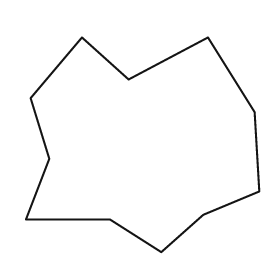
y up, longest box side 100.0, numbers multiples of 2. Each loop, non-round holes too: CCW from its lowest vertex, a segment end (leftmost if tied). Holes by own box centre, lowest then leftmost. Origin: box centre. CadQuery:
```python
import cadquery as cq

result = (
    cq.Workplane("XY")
    .moveTo(8.0, -46.0)
    .lineTo(26.0, -30.0)
    .lineTo(50.0, -20.0)
    .lineTo(48.0, 14.0)
    .lineTo(28.0, 46.0)
    .lineTo(-6.0, 28.0)
    .lineTo(-26.0, 46.0)
    .lineTo(-48.0, 20.0)
    .lineTo(-40.0, -6.0)
    .lineTo(-50.0, -32.0)
    .lineTo(-14.0, -32.0)
    .close()
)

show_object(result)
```